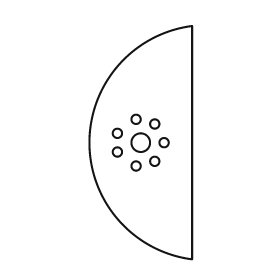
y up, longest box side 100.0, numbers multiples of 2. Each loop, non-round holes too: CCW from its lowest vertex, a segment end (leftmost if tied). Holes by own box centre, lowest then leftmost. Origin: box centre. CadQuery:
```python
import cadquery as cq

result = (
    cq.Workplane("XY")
    .moveTo(22.0, -50.0)
    .lineTo(22.0, 50.0)
    .threePointArc((-22.0, 0.0), (22.0, -50.0))
    .close()
    .moveTo(-2.0, -10.0)
    .circle(2.0)
    .moveTo(6.0, -8.0)
    .circle(2.0)
    .moveTo(-10.0, -4.0)
    .circle(2.0)
    .moveTo(0.0, 0.0)
    .circle(4.0)
    .moveTo(10.0, 0.0)
    .circle(2.0)
    .moveTo(-10.0, 4.0)
    .circle(2.0)
    .moveTo(6.0, 8.0)
    .circle(2.0)
    .moveTo(-2.0, 10.0)
    .circle(2.0)
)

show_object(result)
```